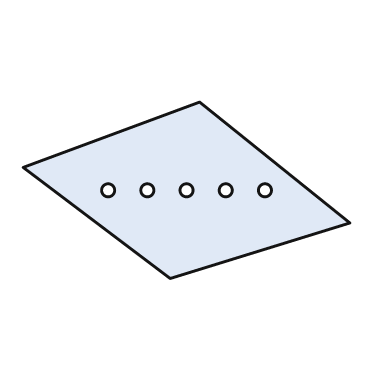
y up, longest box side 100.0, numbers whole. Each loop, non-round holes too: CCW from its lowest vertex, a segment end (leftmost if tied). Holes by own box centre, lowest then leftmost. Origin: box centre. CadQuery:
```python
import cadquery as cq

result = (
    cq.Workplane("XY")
    .moveTo(-5.0, -27.0)
    .lineTo(50.0, -10.0)
    .lineTo(4.0, 27.0)
    .lineTo(-50.0, 7.0)
    .close()
    .moveTo(-24.0, 0.0)
    .circle(2.0)
    .moveTo(-12.0, 0.0)
    .circle(2.0)
    .moveTo(0.0, 0.0)
    .circle(2.0)
    .moveTo(12.0, 0.0)
    .circle(2.0)
    .moveTo(24.0, 0.0)
    .circle(2.0)
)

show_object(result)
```